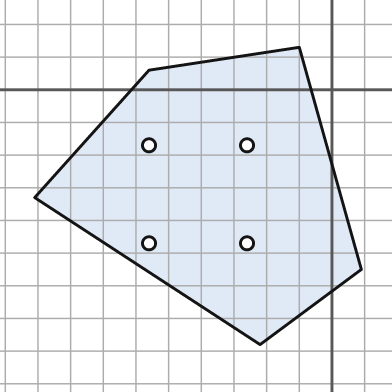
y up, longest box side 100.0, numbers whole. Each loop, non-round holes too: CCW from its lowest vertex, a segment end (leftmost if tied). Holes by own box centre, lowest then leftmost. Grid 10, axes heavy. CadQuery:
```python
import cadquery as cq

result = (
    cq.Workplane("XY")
    .moveTo(-22.0, -78.0)
    .lineTo(9.0, -55.0)
    .lineTo(-10.0, 13.0)
    .lineTo(-56.0, 6.0)
    .lineTo(-91.0, -33.0)
    .close()
    .moveTo(-56.0, -47.0)
    .circle(2.0)
    .moveTo(-26.0, -47.0)
    .circle(2.0)
    .moveTo(-56.0, -17.0)
    .circle(2.0)
    .moveTo(-26.0, -17.0)
    .circle(2.0)
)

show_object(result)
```